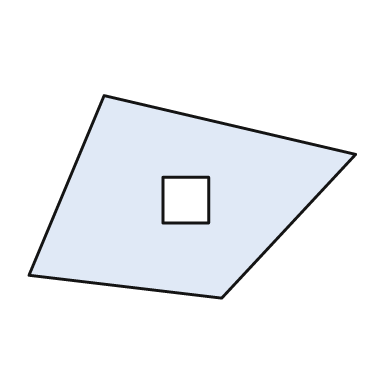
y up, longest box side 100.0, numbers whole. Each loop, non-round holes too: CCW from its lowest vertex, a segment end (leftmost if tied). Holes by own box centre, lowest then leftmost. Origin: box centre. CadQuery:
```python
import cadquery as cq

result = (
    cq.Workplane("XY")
    .moveTo(9.0, -31.0)
    .lineTo(50.0, 13.0)
    .lineTo(-27.0, 31.0)
    .lineTo(-50.0, -24.0)
    .close()
    .moveTo(-9.0, -8.0)
    .lineTo(5.0, -8.0)
    .lineTo(5.0, 6.0)
    .lineTo(-9.0, 6.0)
    .close()
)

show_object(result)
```